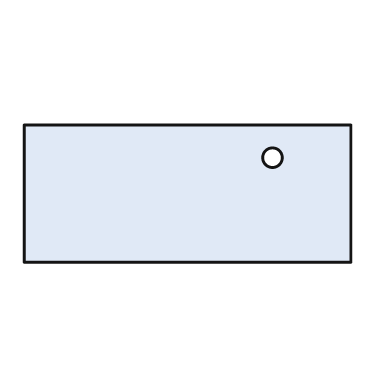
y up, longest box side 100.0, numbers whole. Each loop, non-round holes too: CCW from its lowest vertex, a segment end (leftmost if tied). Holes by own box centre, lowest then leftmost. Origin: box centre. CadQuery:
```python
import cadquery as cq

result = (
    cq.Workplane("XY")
    .moveTo(-50.0, -21.0)
    .lineTo(50.0, -21.0)
    .lineTo(50.0, 21.0)
    .lineTo(-50.0, 21.0)
    .close()
    .moveTo(26.0, 11.0)
    .circle(3.0)
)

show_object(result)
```